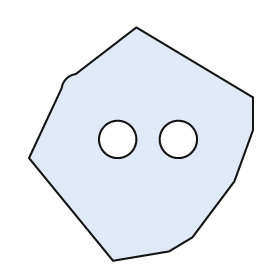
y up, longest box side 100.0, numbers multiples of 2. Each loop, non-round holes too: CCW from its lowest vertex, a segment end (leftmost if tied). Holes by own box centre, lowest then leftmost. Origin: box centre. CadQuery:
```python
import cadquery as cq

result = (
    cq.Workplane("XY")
    .moveTo(-12.0, -50.0)
    .lineTo(12.0, -46.0)
    .lineTo(22.0, -40.0)
    .lineTo(40.0, -16.0)
    .lineTo(48.0, 6.0)
    .lineTo(48.0, 20.0)
    .lineTo(-2.0, 50.0)
    .lineTo(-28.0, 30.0)
    .threePointArc((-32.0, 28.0), (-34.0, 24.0))
    .lineTo(-48.0, -6.0)
    .close()
    .moveTo(-10.0, 2.0)
    .circle(8.0)
    .moveTo(16.0, 2.0)
    .circle(8.0)
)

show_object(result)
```